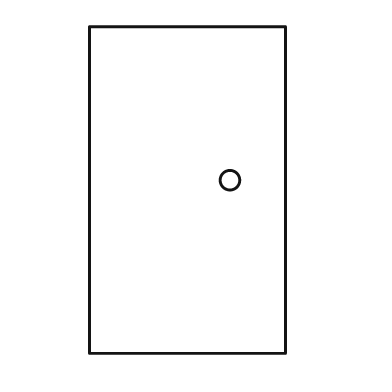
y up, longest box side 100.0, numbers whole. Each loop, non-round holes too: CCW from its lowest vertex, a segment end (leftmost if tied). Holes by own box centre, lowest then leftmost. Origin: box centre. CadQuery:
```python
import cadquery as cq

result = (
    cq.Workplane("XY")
    .moveTo(-30.0, -50.0)
    .lineTo(30.0, -50.0)
    .lineTo(30.0, 50.0)
    .lineTo(-30.0, 50.0)
    .close()
    .moveTo(13.0, 3.0)
    .circle(3.0)
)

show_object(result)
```